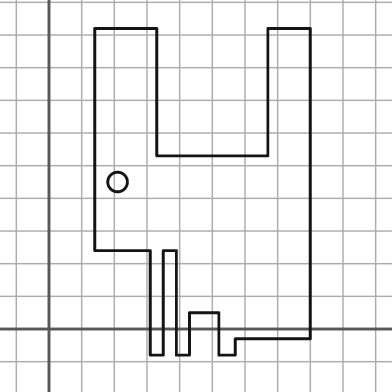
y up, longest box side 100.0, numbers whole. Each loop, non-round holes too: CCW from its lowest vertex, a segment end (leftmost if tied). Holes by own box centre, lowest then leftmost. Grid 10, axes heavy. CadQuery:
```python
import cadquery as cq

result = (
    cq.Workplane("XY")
    .moveTo(31.0, -8.0)
    .lineTo(35.0, -8.0)
    .lineTo(35.0, 24.0)
    .lineTo(39.0, 24.0)
    .lineTo(39.0, -8.0)
    .lineTo(43.0, -8.0)
    .lineTo(43.0, 5.0)
    .lineTo(52.0, 5.0)
    .lineTo(52.0, -8.0)
    .lineTo(57.0, -8.0)
    .lineTo(57.0, -3.0)
    .lineTo(80.0, -3.0)
    .lineTo(80.0, 92.0)
    .lineTo(67.0, 92.0)
    .lineTo(67.0, 53.0)
    .lineTo(33.0, 53.0)
    .lineTo(33.0, 92.0)
    .lineTo(14.0, 92.0)
    .lineTo(14.0, 24.0)
    .lineTo(31.0, 24.0)
    .close()
    .moveTo(21.0, 45.0)
    .circle(3.0)
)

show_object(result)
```